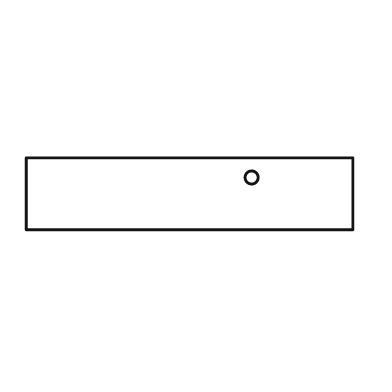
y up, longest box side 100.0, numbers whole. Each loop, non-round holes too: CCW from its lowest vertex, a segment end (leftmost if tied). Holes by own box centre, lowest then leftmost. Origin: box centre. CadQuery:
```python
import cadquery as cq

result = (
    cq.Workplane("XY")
    .moveTo(-50.0, -11.0)
    .lineTo(50.0, -11.0)
    .lineTo(50.0, 11.0)
    .lineTo(-50.0, 11.0)
    .close()
    .moveTo(19.0, 5.0)
    .circle(2.0)
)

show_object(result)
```